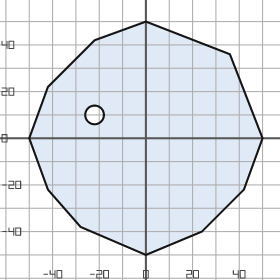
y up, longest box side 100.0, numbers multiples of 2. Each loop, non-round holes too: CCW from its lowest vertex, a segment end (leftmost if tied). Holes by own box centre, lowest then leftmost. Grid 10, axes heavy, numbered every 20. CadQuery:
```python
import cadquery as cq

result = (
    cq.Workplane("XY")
    .moveTo(0.0, -50.0)
    .lineTo(24.0, -40.0)
    .lineTo(42.0, -22.0)
    .lineTo(50.0, 0.0)
    .lineTo(36.0, 36.0)
    .lineTo(0.0, 50.0)
    .lineTo(-22.0, 42.0)
    .lineTo(-42.0, 22.0)
    .lineTo(-50.0, 0.0)
    .lineTo(-42.0, -22.0)
    .lineTo(-28.0, -38.0)
    .close()
    .moveTo(-22.0, 10.0)
    .circle(4.0)
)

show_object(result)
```